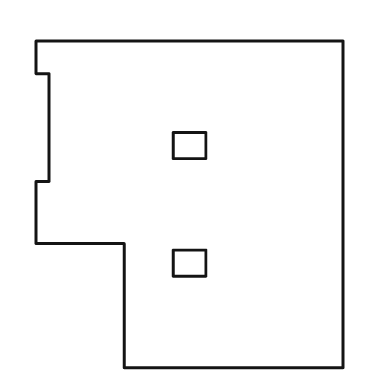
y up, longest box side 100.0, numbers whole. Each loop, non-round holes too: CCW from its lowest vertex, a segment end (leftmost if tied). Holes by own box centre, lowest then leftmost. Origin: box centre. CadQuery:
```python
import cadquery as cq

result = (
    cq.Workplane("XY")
    .moveTo(-20.0, -50.0)
    .lineTo(47.0, -50.0)
    .lineTo(47.0, 50.0)
    .lineTo(-47.0, 50.0)
    .lineTo(-47.0, 40.0)
    .lineTo(-43.0, 40.0)
    .lineTo(-43.0, 7.0)
    .lineTo(-47.0, 7.0)
    .lineTo(-47.0, -12.0)
    .lineTo(-20.0, -12.0)
    .close()
    .moveTo(-5.0, -22.0)
    .lineTo(5.0, -22.0)
    .lineTo(5.0, -14.0)
    .lineTo(-5.0, -14.0)
    .close()
    .moveTo(-5.0, 14.0)
    .lineTo(5.0, 14.0)
    .lineTo(5.0, 22.0)
    .lineTo(-5.0, 22.0)
    .close()
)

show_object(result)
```